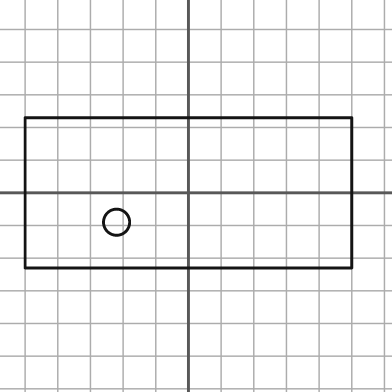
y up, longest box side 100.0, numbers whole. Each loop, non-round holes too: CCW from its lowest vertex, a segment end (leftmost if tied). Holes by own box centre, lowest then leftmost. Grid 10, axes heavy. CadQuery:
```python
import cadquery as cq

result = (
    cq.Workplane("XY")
    .moveTo(-50.0, -23.0)
    .lineTo(50.0, -23.0)
    .lineTo(50.0, 23.0)
    .lineTo(-50.0, 23.0)
    .close()
    .moveTo(-22.0, -9.0)
    .circle(4.0)
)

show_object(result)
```